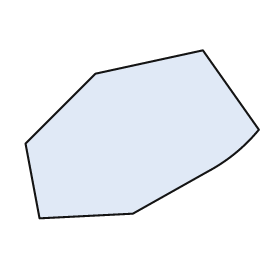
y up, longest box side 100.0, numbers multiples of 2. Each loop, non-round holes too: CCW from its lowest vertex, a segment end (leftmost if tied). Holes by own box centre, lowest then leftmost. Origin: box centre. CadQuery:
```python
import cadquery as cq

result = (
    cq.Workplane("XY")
    .moveTo(-44.0, -36.0)
    .lineTo(-4.0, -34.0)
    .lineTo(28.0, -16.0)
    .threePointArc((40.0, -8.0), (50.0, 2.0))
    .lineTo(26.0, 36.0)
    .lineTo(-20.0, 26.0)
    .lineTo(-50.0, -4.0)
    .close()
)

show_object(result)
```